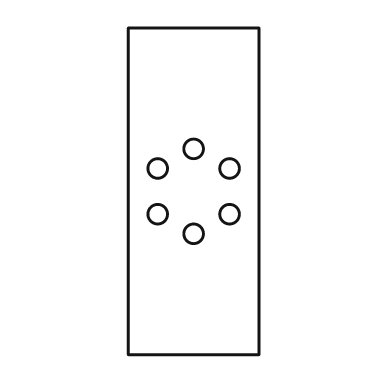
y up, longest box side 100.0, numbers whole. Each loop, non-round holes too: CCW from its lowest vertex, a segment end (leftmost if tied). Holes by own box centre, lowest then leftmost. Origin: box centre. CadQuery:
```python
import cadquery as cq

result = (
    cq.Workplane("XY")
    .moveTo(-20.0, -50.0)
    .lineTo(20.0, -50.0)
    .lineTo(20.0, 50.0)
    .lineTo(-20.0, 50.0)
    .close()
    .moveTo(0.0, -13.0)
    .circle(3.0)
    .moveTo(-11.0, -7.0)
    .circle(3.0)
    .moveTo(11.0, -7.0)
    .circle(3.0)
    .moveTo(-11.0, 7.0)
    .circle(3.0)
    .moveTo(11.0, 7.0)
    .circle(3.0)
    .moveTo(0.0, 13.0)
    .circle(3.0)
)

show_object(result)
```